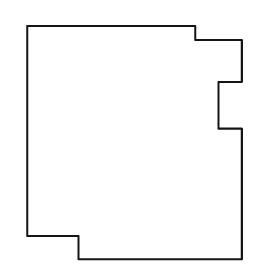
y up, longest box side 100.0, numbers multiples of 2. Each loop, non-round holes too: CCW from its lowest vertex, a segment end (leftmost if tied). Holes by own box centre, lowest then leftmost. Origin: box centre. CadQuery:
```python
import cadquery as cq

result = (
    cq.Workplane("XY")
    .moveTo(-24.0, -50.0)
    .lineTo(46.0, -50.0)
    .lineTo(46.0, 6.0)
    .lineTo(36.0, 6.0)
    .lineTo(36.0, 26.0)
    .lineTo(46.0, 26.0)
    .lineTo(46.0, 44.0)
    .lineTo(26.0, 44.0)
    .lineTo(26.0, 50.0)
    .lineTo(-46.0, 50.0)
    .lineTo(-46.0, -40.0)
    .lineTo(-24.0, -40.0)
    .close()
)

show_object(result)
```